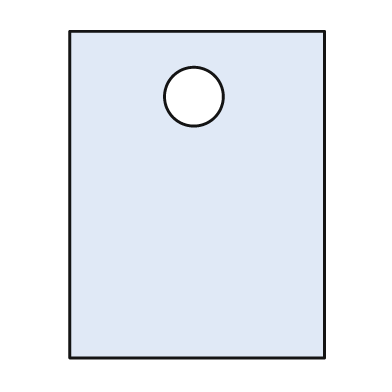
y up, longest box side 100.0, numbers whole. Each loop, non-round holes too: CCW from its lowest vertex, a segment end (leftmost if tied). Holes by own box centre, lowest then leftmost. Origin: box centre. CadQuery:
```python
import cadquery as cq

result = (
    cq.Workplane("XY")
    .moveTo(-39.0, -50.0)
    .lineTo(39.0, -50.0)
    .lineTo(39.0, 50.0)
    .lineTo(-39.0, 50.0)
    .close()
    .moveTo(-1.0, 30.0)
    .circle(9.0)
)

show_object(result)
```